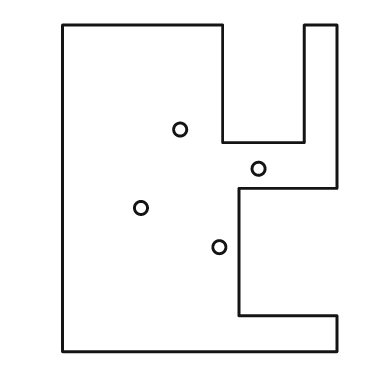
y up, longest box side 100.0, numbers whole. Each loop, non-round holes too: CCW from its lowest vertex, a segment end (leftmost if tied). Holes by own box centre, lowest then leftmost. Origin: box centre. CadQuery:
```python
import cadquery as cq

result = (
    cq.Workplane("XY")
    .moveTo(-42.0, -50.0)
    .lineTo(42.0, -50.0)
    .lineTo(42.0, -39.0)
    .lineTo(12.0, -39.0)
    .lineTo(12.0, 0.0)
    .lineTo(42.0, 0.0)
    .lineTo(42.0, 50.0)
    .lineTo(32.0, 50.0)
    .lineTo(32.0, 14.0)
    .lineTo(7.0, 14.0)
    .lineTo(7.0, 50.0)
    .lineTo(-42.0, 50.0)
    .close()
    .moveTo(6.0, -18.0)
    .circle(2.0)
    .moveTo(-18.0, -6.0)
    .circle(2.0)
    .moveTo(18.0, 6.0)
    .circle(2.0)
    .moveTo(-6.0, 18.0)
    .circle(2.0)
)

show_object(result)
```